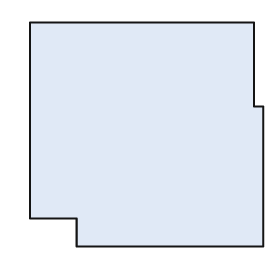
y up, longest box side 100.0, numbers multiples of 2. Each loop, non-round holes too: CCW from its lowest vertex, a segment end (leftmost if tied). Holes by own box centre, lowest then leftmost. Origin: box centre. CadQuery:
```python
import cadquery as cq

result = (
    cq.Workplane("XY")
    .moveTo(-30.0, -48.0)
    .lineTo(50.0, -48.0)
    .lineTo(50.0, 12.0)
    .lineTo(46.0, 12.0)
    .lineTo(46.0, 48.0)
    .lineTo(-50.0, 48.0)
    .lineTo(-50.0, -36.0)
    .lineTo(-30.0, -36.0)
    .close()
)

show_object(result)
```